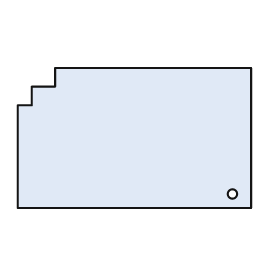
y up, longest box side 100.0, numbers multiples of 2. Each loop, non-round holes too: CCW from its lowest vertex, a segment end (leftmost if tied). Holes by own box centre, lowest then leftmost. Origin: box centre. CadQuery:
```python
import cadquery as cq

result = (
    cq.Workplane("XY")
    .moveTo(-50.0, -30.0)
    .lineTo(50.0, -30.0)
    .lineTo(50.0, 30.0)
    .lineTo(-34.0, 30.0)
    .lineTo(-34.0, 22.0)
    .lineTo(-44.0, 22.0)
    .lineTo(-44.0, 14.0)
    .lineTo(-50.0, 14.0)
    .close()
    .moveTo(42.0, -24.0)
    .circle(2.0)
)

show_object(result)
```